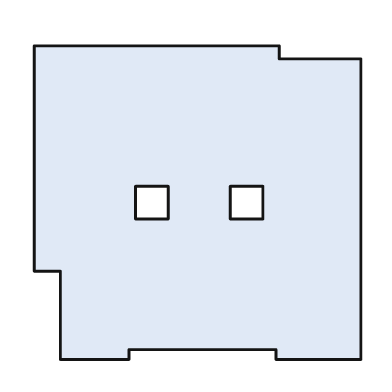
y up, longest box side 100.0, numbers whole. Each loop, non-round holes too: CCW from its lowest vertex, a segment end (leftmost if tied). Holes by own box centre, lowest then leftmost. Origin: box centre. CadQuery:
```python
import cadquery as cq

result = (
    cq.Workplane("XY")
    .moveTo(-42.0, -48.0)
    .lineTo(-21.0, -48.0)
    .lineTo(-21.0, -45.0)
    .lineTo(24.0, -45.0)
    .lineTo(24.0, -48.0)
    .lineTo(50.0, -48.0)
    .lineTo(50.0, 44.0)
    .lineTo(25.0, 44.0)
    .lineTo(25.0, 48.0)
    .lineTo(-50.0, 48.0)
    .lineTo(-50.0, -21.0)
    .lineTo(-42.0, -21.0)
    .close()
    .moveTo(-19.0, -5.0)
    .lineTo(-9.0, -5.0)
    .lineTo(-9.0, 5.0)
    .lineTo(-19.0, 5.0)
    .close()
    .moveTo(10.0, -5.0)
    .lineTo(20.0, -5.0)
    .lineTo(20.0, 5.0)
    .lineTo(10.0, 5.0)
    .close()
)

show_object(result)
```